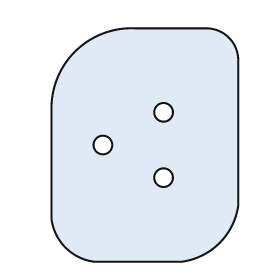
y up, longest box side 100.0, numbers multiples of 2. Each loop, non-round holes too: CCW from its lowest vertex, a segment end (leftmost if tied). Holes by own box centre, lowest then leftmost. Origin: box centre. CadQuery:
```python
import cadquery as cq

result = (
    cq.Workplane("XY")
    .moveTo(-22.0, -50.0)
    .lineTo(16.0, -50.0)
    .threePointArc((32.0, -42.0), (40.0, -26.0))
    .lineTo(40.0, 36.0)
    .threePointArc((36.0, 46.0), (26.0, 50.0))
    .lineTo(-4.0, 50.0)
    .threePointArc((-30.0, 40.0), (-40.0, 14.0))
    .lineTo(-40.0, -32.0)
    .threePointArc((-34.0, -44.0), (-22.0, -50.0))
    .close()
    .moveTo(8.0, -14.0)
    .circle(4.0)
    .moveTo(-18.0, 0.0)
    .circle(4.0)
    .moveTo(8.0, 14.0)
    .circle(4.0)
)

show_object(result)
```